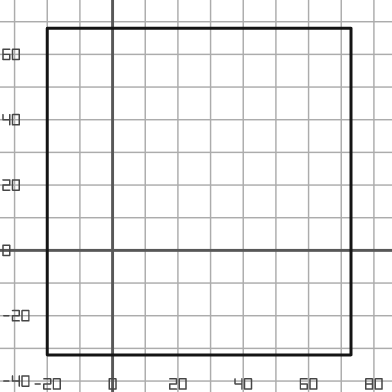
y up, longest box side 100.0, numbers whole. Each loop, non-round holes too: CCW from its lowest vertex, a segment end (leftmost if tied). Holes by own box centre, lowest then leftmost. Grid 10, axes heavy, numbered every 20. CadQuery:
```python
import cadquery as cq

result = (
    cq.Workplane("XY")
    .moveTo(-20.0, -32.0)
    .lineTo(73.0, -32.0)
    .lineTo(73.0, 68.0)
    .lineTo(-20.0, 68.0)
    .close()
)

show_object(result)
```